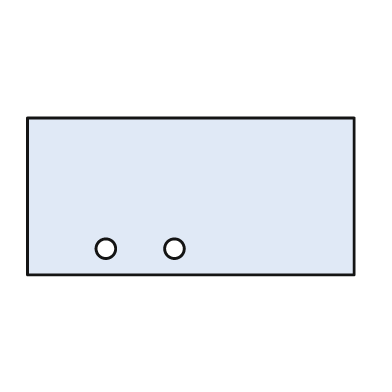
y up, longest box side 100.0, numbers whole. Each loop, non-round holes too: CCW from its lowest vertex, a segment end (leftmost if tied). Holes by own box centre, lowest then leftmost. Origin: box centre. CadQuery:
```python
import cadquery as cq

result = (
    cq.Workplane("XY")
    .moveTo(-50.0, -24.0)
    .lineTo(50.0, -24.0)
    .lineTo(50.0, 24.0)
    .lineTo(-50.0, 24.0)
    .close()
    .moveTo(-26.0, -16.0)
    .circle(3.0)
    .moveTo(-5.0, -16.0)
    .circle(3.0)
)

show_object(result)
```